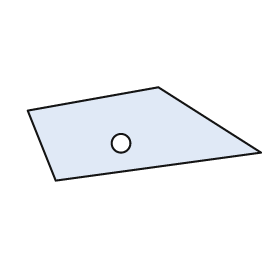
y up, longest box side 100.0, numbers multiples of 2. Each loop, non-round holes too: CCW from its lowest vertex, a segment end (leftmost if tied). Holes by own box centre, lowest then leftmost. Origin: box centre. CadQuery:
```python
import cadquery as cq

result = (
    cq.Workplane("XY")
    .moveTo(-38.0, -20.0)
    .lineTo(50.0, -8.0)
    .lineTo(6.0, 20.0)
    .lineTo(-50.0, 10.0)
    .close()
    .moveTo(-10.0, -4.0)
    .circle(4.0)
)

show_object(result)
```